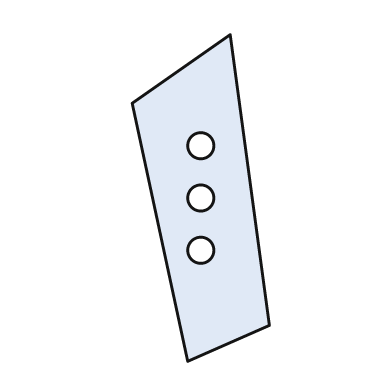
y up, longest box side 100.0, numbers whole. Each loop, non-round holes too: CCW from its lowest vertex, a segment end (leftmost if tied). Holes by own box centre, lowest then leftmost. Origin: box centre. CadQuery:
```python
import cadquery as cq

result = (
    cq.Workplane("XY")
    .moveTo(-4.0, -50.0)
    .lineTo(21.0, -39.0)
    .lineTo(9.0, 50.0)
    .lineTo(-21.0, 29.0)
    .close()
    .moveTo(0.0, -16.0)
    .circle(4.0)
    .moveTo(0.0, 0.0)
    .circle(4.0)
    .moveTo(0.0, 16.0)
    .circle(4.0)
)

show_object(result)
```